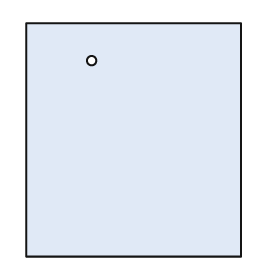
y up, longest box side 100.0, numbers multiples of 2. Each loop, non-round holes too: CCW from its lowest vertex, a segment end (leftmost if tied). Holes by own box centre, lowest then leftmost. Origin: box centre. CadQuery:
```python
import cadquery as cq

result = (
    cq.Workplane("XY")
    .moveTo(-46.0, -50.0)
    .lineTo(46.0, -50.0)
    .lineTo(46.0, 50.0)
    .lineTo(-46.0, 50.0)
    .close()
    .moveTo(-18.0, 34.0)
    .circle(2.0)
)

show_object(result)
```